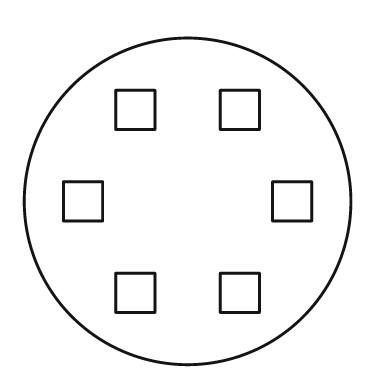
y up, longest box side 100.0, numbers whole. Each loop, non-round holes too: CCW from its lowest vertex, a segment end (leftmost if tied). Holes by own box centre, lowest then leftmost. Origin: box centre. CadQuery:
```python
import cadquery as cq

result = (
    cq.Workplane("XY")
    .moveTo(0.0, 0.0)
    .circle(50.0)
    .moveTo(-22.0, -34.0)
    .lineTo(-10.0, -34.0)
    .lineTo(-10.0, -22.0)
    .lineTo(-22.0, -22.0)
    .close()
    .moveTo(10.0, -34.0)
    .lineTo(22.0, -34.0)
    .lineTo(22.0, -22.0)
    .lineTo(10.0, -22.0)
    .close()
    .moveTo(-38.0, -6.0)
    .lineTo(-26.0, -6.0)
    .lineTo(-26.0, 6.0)
    .lineTo(-38.0, 6.0)
    .close()
    .moveTo(26.0, -6.0)
    .lineTo(38.0, -6.0)
    .lineTo(38.0, 6.0)
    .lineTo(26.0, 6.0)
    .close()
    .moveTo(-22.0, 22.0)
    .lineTo(-10.0, 22.0)
    .lineTo(-10.0, 34.0)
    .lineTo(-22.0, 34.0)
    .close()
    .moveTo(10.0, 22.0)
    .lineTo(22.0, 22.0)
    .lineTo(22.0, 34.0)
    .lineTo(10.0, 34.0)
    .close()
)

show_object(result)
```